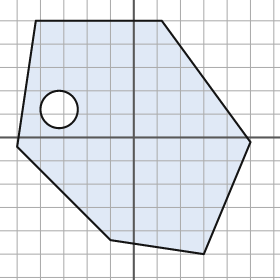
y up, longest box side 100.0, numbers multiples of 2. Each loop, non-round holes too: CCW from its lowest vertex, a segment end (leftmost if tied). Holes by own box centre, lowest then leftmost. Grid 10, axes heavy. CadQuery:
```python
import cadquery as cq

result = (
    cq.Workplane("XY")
    .moveTo(30.0, -50.0)
    .lineTo(50.0, -2.0)
    .lineTo(12.0, 50.0)
    .lineTo(-42.0, 50.0)
    .lineTo(-50.0, -4.0)
    .lineTo(-10.0, -44.0)
    .close()
    .moveTo(-32.0, 12.0)
    .circle(8.0)
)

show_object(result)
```